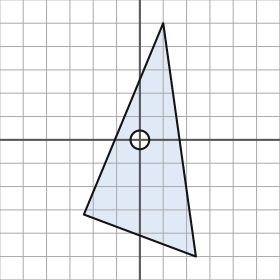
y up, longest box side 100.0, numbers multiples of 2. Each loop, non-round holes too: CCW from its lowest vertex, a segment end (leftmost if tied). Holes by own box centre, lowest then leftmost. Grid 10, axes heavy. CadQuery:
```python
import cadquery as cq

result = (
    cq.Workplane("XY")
    .moveTo(24.0, -50.0)
    .lineTo(10.0, 50.0)
    .lineTo(-24.0, -32.0)
    .close()
    .moveTo(0.0, 0.0)
    .circle(4.0)
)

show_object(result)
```